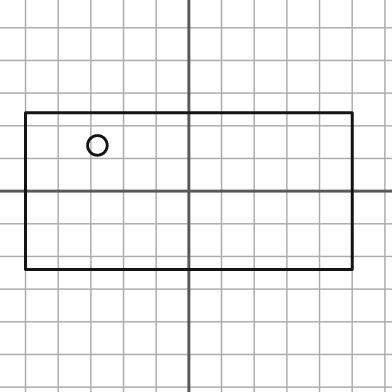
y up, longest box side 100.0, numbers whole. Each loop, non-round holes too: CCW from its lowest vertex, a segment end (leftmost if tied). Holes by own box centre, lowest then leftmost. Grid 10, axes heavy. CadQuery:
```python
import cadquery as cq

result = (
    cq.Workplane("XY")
    .moveTo(-50.0, -24.0)
    .lineTo(50.0, -24.0)
    .lineTo(50.0, 24.0)
    .lineTo(-50.0, 24.0)
    .close()
    .moveTo(-28.0, 14.0)
    .circle(3.0)
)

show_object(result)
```